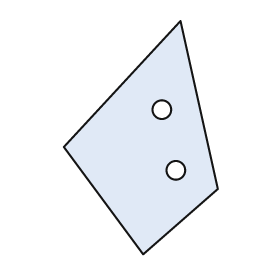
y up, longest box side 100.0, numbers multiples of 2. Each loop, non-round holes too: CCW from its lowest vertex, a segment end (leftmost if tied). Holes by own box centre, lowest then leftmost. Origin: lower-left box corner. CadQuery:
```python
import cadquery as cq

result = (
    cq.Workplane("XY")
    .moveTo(34.0, 0.0)
    .lineTo(66.0, 28.0)
    .lineTo(50.0, 100.0)
    .lineTo(0.0, 46.0)
    .close()
    .moveTo(48.0, 36.0)
    .circle(4.0)
    .moveTo(42.0, 62.0)
    .circle(4.0)
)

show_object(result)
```